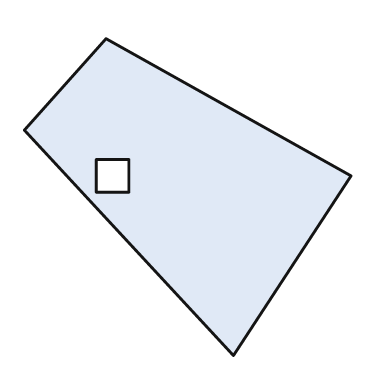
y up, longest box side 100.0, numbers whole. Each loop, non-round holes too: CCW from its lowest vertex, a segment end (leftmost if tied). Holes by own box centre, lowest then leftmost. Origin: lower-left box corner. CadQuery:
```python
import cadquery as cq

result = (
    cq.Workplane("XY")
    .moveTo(64.0, 0.0)
    .lineTo(100.0, 55.0)
    .lineTo(25.0, 97.0)
    .lineTo(0.0, 69.0)
    .close()
    .moveTo(22.0, 50.0)
    .lineTo(32.0, 50.0)
    .lineTo(32.0, 60.0)
    .lineTo(22.0, 60.0)
    .close()
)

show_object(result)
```